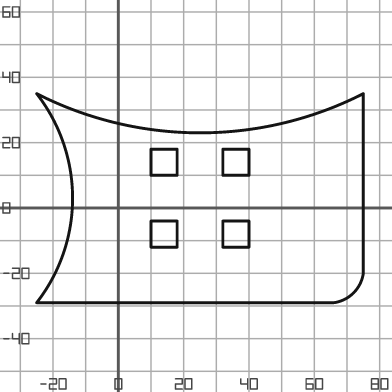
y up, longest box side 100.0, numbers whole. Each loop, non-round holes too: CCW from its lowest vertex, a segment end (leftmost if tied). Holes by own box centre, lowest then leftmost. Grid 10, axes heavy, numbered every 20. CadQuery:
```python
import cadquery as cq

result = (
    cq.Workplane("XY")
    .moveTo(-25.0, -29.0)
    .lineTo(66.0, -29.0)
    .threePointArc((72.0, -26.0), (75.0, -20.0))
    .lineTo(75.0, 35.0)
    .threePointArc((25.0, 23.0), (-25.0, 35.0))
    .threePointArc((-14.0, 3.0), (-25.0, -29.0))
    .close()
    .moveTo(10.0, -12.0)
    .lineTo(18.0, -12.0)
    .lineTo(18.0, -4.0)
    .lineTo(10.0, -4.0)
    .close()
    .moveTo(32.0, -12.0)
    .lineTo(40.0, -12.0)
    .lineTo(40.0, -4.0)
    .lineTo(32.0, -4.0)
    .close()
    .moveTo(10.0, 10.0)
    .lineTo(18.0, 10.0)
    .lineTo(18.0, 18.0)
    .lineTo(10.0, 18.0)
    .close()
    .moveTo(32.0, 10.0)
    .lineTo(40.0, 10.0)
    .lineTo(40.0, 18.0)
    .lineTo(32.0, 18.0)
    .close()
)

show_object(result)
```